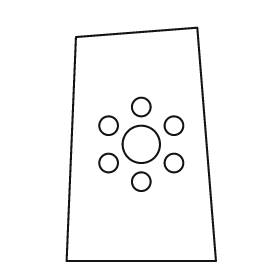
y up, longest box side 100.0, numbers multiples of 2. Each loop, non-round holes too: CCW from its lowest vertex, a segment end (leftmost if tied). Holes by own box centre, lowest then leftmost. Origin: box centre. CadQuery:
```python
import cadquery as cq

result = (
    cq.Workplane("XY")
    .moveTo(-32.0, -50.0)
    .lineTo(32.0, -50.0)
    .lineTo(24.0, 50.0)
    .lineTo(-28.0, 46.0)
    .close()
    .moveTo(0.0, -16.0)
    .circle(4.0)
    .moveTo(-14.0, -8.0)
    .circle(4.0)
    .moveTo(14.0, -8.0)
    .circle(4.0)
    .moveTo(0.0, 0.0)
    .circle(8.0)
    .moveTo(-14.0, 8.0)
    .circle(4.0)
    .moveTo(14.0, 8.0)
    .circle(4.0)
    .moveTo(0.0, 16.0)
    .circle(4.0)
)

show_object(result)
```